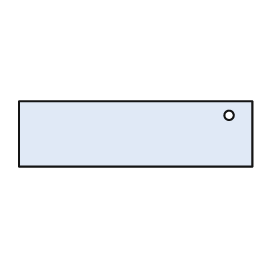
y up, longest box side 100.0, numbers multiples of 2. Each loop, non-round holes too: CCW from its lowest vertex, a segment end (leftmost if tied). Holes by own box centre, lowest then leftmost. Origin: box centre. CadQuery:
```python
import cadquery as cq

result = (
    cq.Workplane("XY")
    .moveTo(-50.0, -14.0)
    .lineTo(50.0, -14.0)
    .lineTo(50.0, 14.0)
    .lineTo(-50.0, 14.0)
    .close()
    .moveTo(40.0, 8.0)
    .circle(2.0)
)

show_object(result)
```